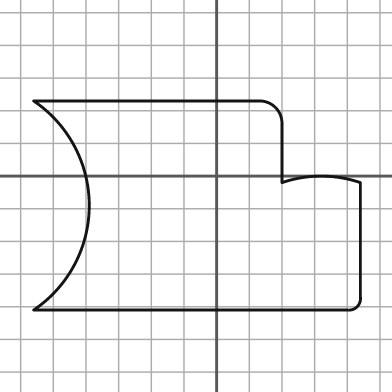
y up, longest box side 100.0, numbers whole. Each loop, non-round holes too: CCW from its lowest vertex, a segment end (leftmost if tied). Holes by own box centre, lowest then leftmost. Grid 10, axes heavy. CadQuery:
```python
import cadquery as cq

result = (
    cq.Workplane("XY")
    .moveTo(-56.0, -41.0)
    .lineTo(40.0, -41.0)
    .threePointArc((43.0, -40.0), (44.0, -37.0))
    .lineTo(44.0, -2.0)
    .threePointArc((32.0, 0.0), (20.0, -2.0))
    .lineTo(20.0, 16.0)
    .threePointArc((18.0, 21.0), (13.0, 23.0))
    .lineTo(-56.0, 23.0)
    .threePointArc((-39.0, -9.0), (-56.0, -41.0))
    .close()
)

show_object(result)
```